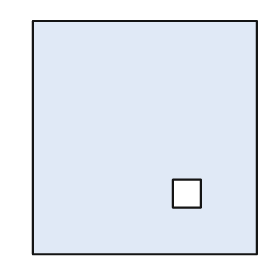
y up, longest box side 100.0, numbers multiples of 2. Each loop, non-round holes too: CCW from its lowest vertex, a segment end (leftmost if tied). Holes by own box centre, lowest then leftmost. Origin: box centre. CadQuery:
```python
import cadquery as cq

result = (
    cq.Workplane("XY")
    .moveTo(-48.0, -50.0)
    .lineTo(48.0, -50.0)
    .lineTo(48.0, 50.0)
    .lineTo(-48.0, 50.0)
    .close()
    .moveTo(12.0, -30.0)
    .lineTo(24.0, -30.0)
    .lineTo(24.0, -18.0)
    .lineTo(12.0, -18.0)
    .close()
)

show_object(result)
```